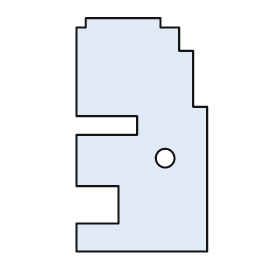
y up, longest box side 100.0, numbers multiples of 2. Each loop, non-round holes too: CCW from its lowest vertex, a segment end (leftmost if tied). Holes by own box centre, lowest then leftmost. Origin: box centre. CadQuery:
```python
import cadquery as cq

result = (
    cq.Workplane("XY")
    .moveTo(-28.0, -50.0)
    .lineTo(28.0, -50.0)
    .lineTo(28.0, 12.0)
    .lineTo(22.0, 12.0)
    .lineTo(22.0, 36.0)
    .lineTo(16.0, 36.0)
    .lineTo(16.0, 46.0)
    .lineTo(8.0, 46.0)
    .lineTo(8.0, 50.0)
    .lineTo(-24.0, 50.0)
    .lineTo(-24.0, 46.0)
    .lineTo(-28.0, 46.0)
    .lineTo(-28.0, 8.0)
    .lineTo(-2.0, 8.0)
    .lineTo(-2.0, 0.0)
    .lineTo(-28.0, 0.0)
    .lineTo(-28.0, -22.0)
    .lineTo(-10.0, -22.0)
    .lineTo(-10.0, -38.0)
    .lineTo(-28.0, -38.0)
    .close()
    .moveTo(10.0, -10.0)
    .circle(4.0)
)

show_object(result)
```